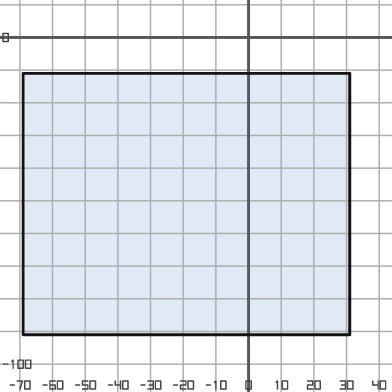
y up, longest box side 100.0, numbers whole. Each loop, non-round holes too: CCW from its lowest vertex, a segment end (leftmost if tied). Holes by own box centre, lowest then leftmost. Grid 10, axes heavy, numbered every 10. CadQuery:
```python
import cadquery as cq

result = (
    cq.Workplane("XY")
    .moveTo(-69.0, -91.0)
    .lineTo(31.0, -91.0)
    .lineTo(31.0, -11.0)
    .lineTo(-69.0, -11.0)
    .close()
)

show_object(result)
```